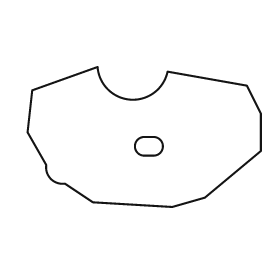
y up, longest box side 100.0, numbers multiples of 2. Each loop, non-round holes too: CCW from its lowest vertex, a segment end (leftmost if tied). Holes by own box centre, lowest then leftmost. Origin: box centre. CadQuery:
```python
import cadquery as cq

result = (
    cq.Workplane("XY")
    .moveTo(12.0, -30.0)
    .lineTo(26.0, -26.0)
    .lineTo(50.0, -6.0)
    .lineTo(50.0, 10.0)
    .lineTo(44.0, 22.0)
    .lineTo(10.0, 28.0)
    .threePointArc((-6.0, 16.0), (-20.0, 30.0))
    .lineTo(-48.0, 20.0)
    .lineTo(-50.0, 2.0)
    .lineTo(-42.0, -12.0)
    .threePointArc((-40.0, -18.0), (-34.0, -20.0))
    .lineTo(-22.0, -28.0)
    .close()
    .moveTo(0.0, -8.0)
    .lineTo(4.0, -8.0)
    .threePointArc((8.0, -4.0), (4.0, 0.0))
    .lineTo(0.0, 0.0)
    .threePointArc((-4.0, -4.0), (0.0, -8.0))
    .close()
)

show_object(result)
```